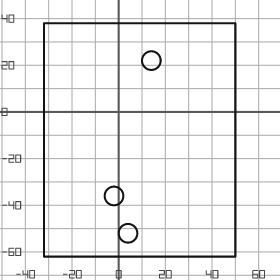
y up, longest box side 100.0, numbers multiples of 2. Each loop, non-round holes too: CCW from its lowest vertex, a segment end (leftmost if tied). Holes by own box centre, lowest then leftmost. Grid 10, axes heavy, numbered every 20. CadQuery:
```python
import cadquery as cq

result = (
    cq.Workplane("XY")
    .moveTo(-32.0, -62.0)
    .lineTo(50.0, -62.0)
    .lineTo(50.0, 38.0)
    .lineTo(-32.0, 38.0)
    .close()
    .moveTo(4.0, -52.0)
    .circle(4.0)
    .moveTo(-2.0, -36.0)
    .circle(4.0)
    .moveTo(14.0, 22.0)
    .circle(4.0)
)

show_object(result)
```